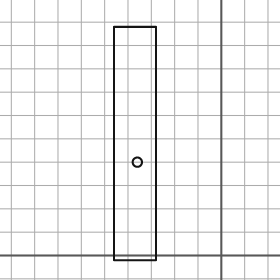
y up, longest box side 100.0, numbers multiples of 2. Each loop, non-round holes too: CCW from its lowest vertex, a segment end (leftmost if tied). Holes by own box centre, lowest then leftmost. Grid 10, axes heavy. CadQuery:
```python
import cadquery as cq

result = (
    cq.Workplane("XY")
    .moveTo(-46.0, -2.0)
    .lineTo(-28.0, -2.0)
    .lineTo(-28.0, 98.0)
    .lineTo(-46.0, 98.0)
    .close()
    .moveTo(-36.0, 40.0)
    .circle(2.0)
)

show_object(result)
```